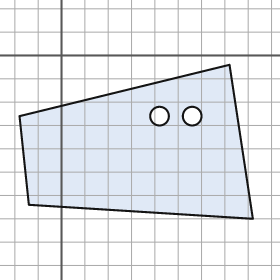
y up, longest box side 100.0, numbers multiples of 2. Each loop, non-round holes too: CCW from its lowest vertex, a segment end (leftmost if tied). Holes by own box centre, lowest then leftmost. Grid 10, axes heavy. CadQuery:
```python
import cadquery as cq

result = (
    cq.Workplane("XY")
    .moveTo(82.0, -70.0)
    .lineTo(72.0, -4.0)
    .lineTo(-18.0, -26.0)
    .lineTo(-14.0, -64.0)
    .close()
    .moveTo(42.0, -26.0)
    .circle(4.0)
    .moveTo(56.0, -26.0)
    .circle(4.0)
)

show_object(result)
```